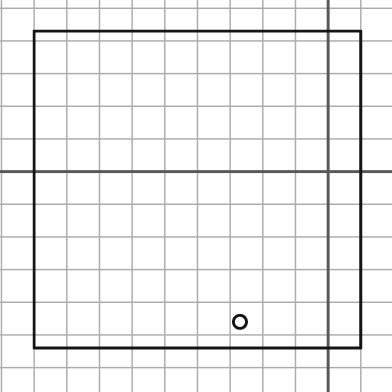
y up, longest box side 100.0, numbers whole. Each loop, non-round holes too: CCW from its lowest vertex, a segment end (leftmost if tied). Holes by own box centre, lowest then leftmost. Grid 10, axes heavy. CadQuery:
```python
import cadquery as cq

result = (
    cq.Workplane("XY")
    .moveTo(-90.0, -54.0)
    .lineTo(10.0, -54.0)
    .lineTo(10.0, 43.0)
    .lineTo(-90.0, 43.0)
    .close()
    .moveTo(-27.0, -46.0)
    .circle(2.0)
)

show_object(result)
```